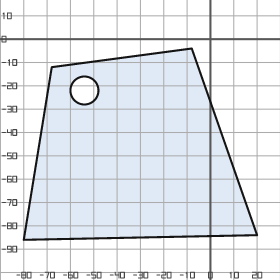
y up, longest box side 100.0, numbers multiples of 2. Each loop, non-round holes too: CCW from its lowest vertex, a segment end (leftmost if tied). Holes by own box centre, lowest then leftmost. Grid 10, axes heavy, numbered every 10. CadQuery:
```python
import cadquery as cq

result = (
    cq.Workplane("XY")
    .moveTo(-80.0, -86.0)
    .lineTo(20.0, -84.0)
    .lineTo(-8.0, -4.0)
    .lineTo(-68.0, -12.0)
    .close()
    .moveTo(-54.0, -22.0)
    .circle(6.0)
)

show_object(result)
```